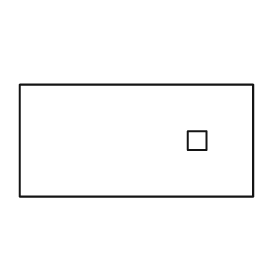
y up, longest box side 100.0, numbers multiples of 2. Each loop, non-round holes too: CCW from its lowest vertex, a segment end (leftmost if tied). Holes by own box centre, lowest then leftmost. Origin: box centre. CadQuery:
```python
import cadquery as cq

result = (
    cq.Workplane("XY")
    .moveTo(-50.0, -24.0)
    .lineTo(50.0, -24.0)
    .lineTo(50.0, 24.0)
    .lineTo(-50.0, 24.0)
    .close()
    .moveTo(22.0, -4.0)
    .lineTo(30.0, -4.0)
    .lineTo(30.0, 4.0)
    .lineTo(22.0, 4.0)
    .close()
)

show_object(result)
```